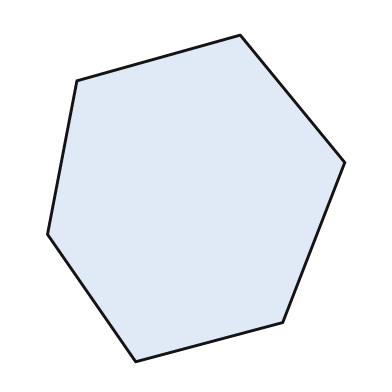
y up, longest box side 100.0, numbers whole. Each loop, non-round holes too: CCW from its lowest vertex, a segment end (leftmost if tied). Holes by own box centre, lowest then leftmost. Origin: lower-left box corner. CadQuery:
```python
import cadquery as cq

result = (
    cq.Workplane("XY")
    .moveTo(27.0, 0.0)
    .lineTo(72.0, 12.0)
    .lineTo(91.0, 61.0)
    .lineTo(59.0, 100.0)
    .lineTo(9.0, 86.0)
    .lineTo(0.0, 39.0)
    .close()
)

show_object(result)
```